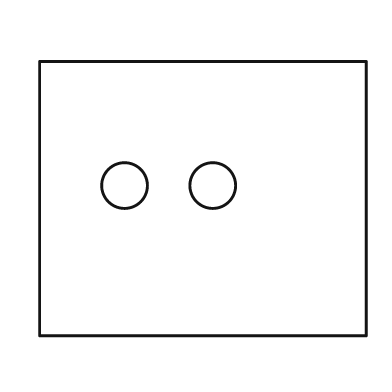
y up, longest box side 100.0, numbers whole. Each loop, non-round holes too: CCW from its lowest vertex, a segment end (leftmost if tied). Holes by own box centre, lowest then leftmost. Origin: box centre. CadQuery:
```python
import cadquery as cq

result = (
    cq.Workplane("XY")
    .moveTo(-50.0, -42.0)
    .lineTo(50.0, -42.0)
    .lineTo(50.0, 42.0)
    .lineTo(-50.0, 42.0)
    .close()
    .moveTo(-24.0, 4.0)
    .circle(7.0)
    .moveTo(3.0, 4.0)
    .circle(7.0)
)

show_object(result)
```